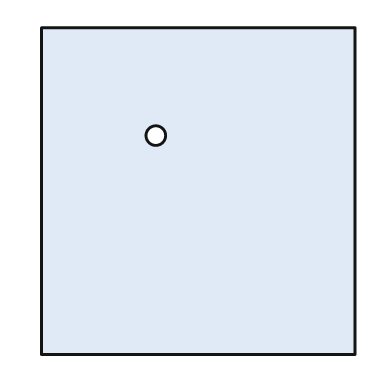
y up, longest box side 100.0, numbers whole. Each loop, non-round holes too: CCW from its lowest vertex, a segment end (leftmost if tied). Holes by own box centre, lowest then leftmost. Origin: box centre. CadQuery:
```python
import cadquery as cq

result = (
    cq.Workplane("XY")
    .moveTo(-48.0, -50.0)
    .lineTo(48.0, -50.0)
    .lineTo(48.0, 50.0)
    .lineTo(-48.0, 50.0)
    .close()
    .moveTo(-13.0, 17.0)
    .circle(3.0)
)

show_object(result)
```